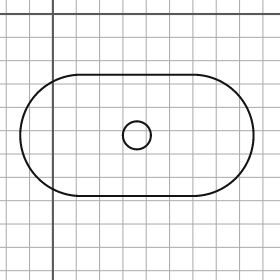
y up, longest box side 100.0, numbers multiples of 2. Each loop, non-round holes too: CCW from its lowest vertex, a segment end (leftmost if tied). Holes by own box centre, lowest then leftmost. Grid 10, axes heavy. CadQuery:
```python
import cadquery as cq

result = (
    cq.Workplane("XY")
    .moveTo(12.0, -78.0)
    .lineTo(60.0, -78.0)
    .threePointArc((86.0, -52.0), (60.0, -26.0))
    .lineTo(12.0, -26.0)
    .threePointArc((-14.0, -52.0), (12.0, -78.0))
    .close()
    .moveTo(36.0, -52.0)
    .circle(6.0)
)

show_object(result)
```